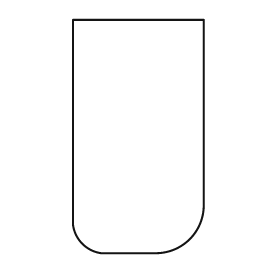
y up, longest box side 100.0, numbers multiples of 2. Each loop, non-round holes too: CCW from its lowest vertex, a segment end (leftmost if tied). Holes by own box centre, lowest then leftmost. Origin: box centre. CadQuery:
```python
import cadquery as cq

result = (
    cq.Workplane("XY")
    .moveTo(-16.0, -50.0)
    .lineTo(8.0, -50.0)
    .threePointArc((22.0, -44.0), (28.0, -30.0))
    .lineTo(28.0, 50.0)
    .lineTo(-28.0, 50.0)
    .lineTo(-28.0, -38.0)
    .threePointArc((-24.0, -46.0), (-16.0, -50.0))
    .close()
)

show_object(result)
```